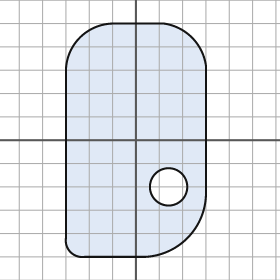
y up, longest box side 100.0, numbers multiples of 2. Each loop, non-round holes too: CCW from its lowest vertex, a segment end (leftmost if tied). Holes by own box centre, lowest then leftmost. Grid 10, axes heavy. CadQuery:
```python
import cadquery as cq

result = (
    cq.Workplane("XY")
    .moveTo(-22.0, -50.0)
    .lineTo(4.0, -50.0)
    .threePointArc((22.0, -42.0), (30.0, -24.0))
    .lineTo(30.0, 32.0)
    .threePointArc((24.0, 44.0), (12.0, 50.0))
    .lineTo(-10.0, 50.0)
    .threePointArc((-24.0, 44.0), (-30.0, 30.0))
    .lineTo(-30.0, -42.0)
    .threePointArc((-28.0, -48.0), (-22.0, -50.0))
    .close()
    .moveTo(14.0, -20.0)
    .circle(8.0)
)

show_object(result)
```